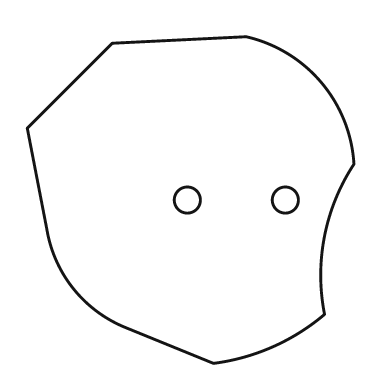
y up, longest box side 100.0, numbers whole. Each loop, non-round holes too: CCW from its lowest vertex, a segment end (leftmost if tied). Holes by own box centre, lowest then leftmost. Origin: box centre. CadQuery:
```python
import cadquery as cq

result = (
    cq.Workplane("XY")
    .moveTo(7.0, -50.0)
    .threePointArc((25.0, -45.0), (41.0, -35.0))
    .threePointArc((41.0, -11.0), (50.0, 11.0))
    .threePointArc((40.0, 36.0), (17.0, 50.0))
    .lineTo(-24.0, 48.0)
    .lineTo(-50.0, 22.0)
    .lineTo(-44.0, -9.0)
    .threePointArc((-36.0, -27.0), (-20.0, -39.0))
    .close()
    .moveTo(-1.0, 0.0)
    .circle(4.0)
    .moveTo(29.0, 0.0)
    .circle(4.0)
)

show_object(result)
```